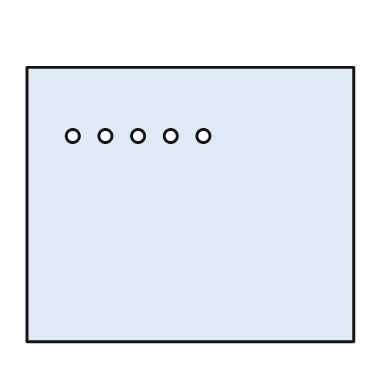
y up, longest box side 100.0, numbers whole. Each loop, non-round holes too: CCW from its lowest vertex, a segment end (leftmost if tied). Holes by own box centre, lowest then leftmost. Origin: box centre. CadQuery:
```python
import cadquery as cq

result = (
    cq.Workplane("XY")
    .moveTo(-50.0, -42.0)
    .lineTo(50.0, -42.0)
    .lineTo(50.0, 42.0)
    .lineTo(-50.0, 42.0)
    .close()
    .moveTo(-36.0, 21.0)
    .circle(2.0)
    .moveTo(-26.0, 21.0)
    .circle(2.0)
    .moveTo(-16.0, 21.0)
    .circle(2.0)
    .moveTo(-6.0, 21.0)
    .circle(2.0)
    .moveTo(4.0, 21.0)
    .circle(2.0)
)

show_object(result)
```